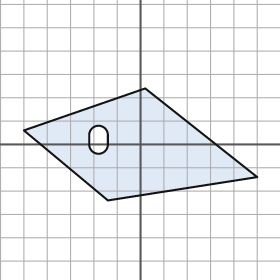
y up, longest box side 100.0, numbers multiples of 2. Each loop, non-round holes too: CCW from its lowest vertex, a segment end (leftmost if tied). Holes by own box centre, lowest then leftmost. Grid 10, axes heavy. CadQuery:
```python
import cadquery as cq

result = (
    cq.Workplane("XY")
    .moveTo(-14.0, -24.0)
    .lineTo(50.0, -14.0)
    .lineTo(2.0, 24.0)
    .lineTo(-50.0, 6.0)
    .close()
    .moveTo(-22.0, 0.0)
    .threePointArc((-18.0, -4.0), (-14.0, 0.0))
    .lineTo(-14.0, 4.0)
    .threePointArc((-18.0, 8.0), (-22.0, 4.0))
    .close()
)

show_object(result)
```